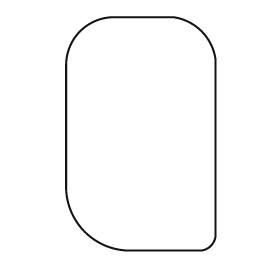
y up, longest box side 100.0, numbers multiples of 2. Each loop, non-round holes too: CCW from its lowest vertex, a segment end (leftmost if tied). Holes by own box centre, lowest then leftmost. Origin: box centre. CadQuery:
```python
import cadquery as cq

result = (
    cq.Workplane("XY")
    .moveTo(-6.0, -50.0)
    .lineTo(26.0, -50.0)
    .threePointArc((30.0, -48.0), (32.0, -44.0))
    .lineTo(32.0, 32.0)
    .threePointArc((26.0, 44.0), (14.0, 50.0))
    .lineTo(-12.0, 50.0)
    .threePointArc((-26.0, 44.0), (-32.0, 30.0))
    .lineTo(-32.0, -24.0)
    .threePointArc((-24.0, -42.0), (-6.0, -50.0))
    .close()
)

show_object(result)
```